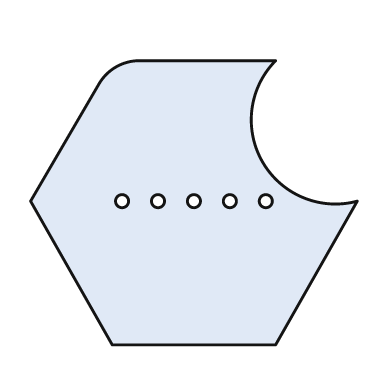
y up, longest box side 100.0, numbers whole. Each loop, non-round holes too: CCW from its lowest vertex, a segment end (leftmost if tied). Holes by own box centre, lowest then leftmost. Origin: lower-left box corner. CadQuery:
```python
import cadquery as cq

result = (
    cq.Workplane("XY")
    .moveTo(25.0, 0.0)
    .lineTo(75.0, 0.0)
    .lineTo(100.0, 44.0)
    .threePointArc((71.0, 56.0), (75.0, 87.0))
    .lineTo(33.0, 87.0)
    .threePointArc((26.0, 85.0), (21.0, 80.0))
    .lineTo(0.0, 44.0)
    .close()
    .moveTo(28.0, 44.0)
    .circle(2.0)
    .moveTo(39.0, 44.0)
    .circle(2.0)
    .moveTo(50.0, 44.0)
    .circle(2.0)
    .moveTo(61.0, 44.0)
    .circle(2.0)
    .moveTo(72.0, 44.0)
    .circle(2.0)
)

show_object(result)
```